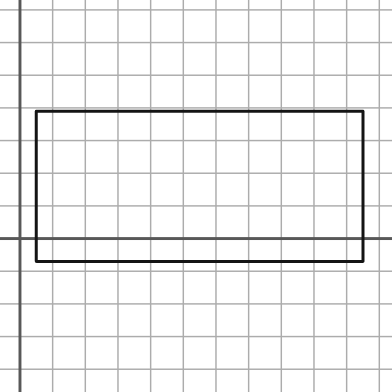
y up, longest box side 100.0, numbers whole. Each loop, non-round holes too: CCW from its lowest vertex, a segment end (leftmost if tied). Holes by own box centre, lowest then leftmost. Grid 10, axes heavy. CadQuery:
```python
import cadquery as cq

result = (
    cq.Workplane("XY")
    .moveTo(5.0, -7.0)
    .lineTo(105.0, -7.0)
    .lineTo(105.0, 39.0)
    .lineTo(5.0, 39.0)
    .close()
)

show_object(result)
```